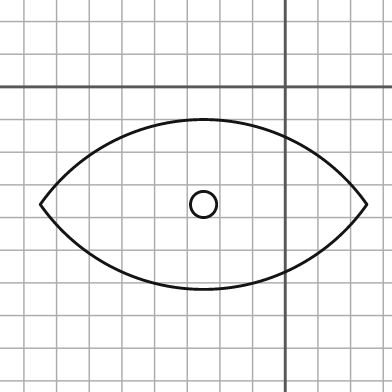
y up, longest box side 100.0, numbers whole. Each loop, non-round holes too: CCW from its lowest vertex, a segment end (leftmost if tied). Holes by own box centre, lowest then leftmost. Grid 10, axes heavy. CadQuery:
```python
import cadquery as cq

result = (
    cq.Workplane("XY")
    .moveTo(-75.0, -36.0)
    .threePointArc((-25.0, -62.0), (25.0, -36.0))
    .threePointArc((-25.0, -10.0), (-75.0, -36.0))
    .close()
    .moveTo(-25.0, -36.0)
    .circle(4.0)
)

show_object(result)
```